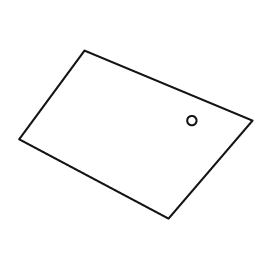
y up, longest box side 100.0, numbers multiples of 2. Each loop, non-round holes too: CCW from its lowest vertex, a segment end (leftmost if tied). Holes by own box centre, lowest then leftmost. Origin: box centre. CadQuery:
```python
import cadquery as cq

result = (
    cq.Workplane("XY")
    .moveTo(14.0, -36.0)
    .lineTo(50.0, 6.0)
    .lineTo(-22.0, 36.0)
    .lineTo(-50.0, -2.0)
    .close()
    .moveTo(24.0, 6.0)
    .circle(2.0)
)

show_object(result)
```